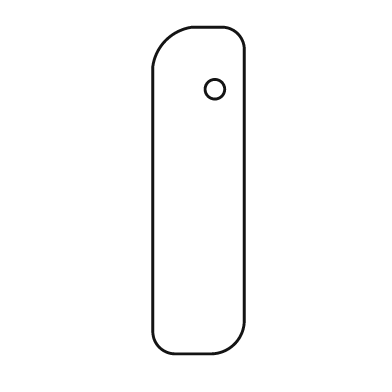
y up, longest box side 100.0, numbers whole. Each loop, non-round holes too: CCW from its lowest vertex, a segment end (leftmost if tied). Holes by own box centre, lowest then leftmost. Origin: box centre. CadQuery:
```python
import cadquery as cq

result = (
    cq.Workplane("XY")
    .moveTo(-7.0, -50.0)
    .lineTo(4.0, -50.0)
    .threePointArc((11.0, -47.0), (14.0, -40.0))
    .lineTo(14.0, 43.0)
    .threePointArc((12.0, 48.0), (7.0, 50.0))
    .lineTo(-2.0, 50.0)
    .threePointArc((-10.0, 46.0), (-14.0, 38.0))
    .lineTo(-14.0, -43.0)
    .threePointArc((-12.0, -48.0), (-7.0, -50.0))
    .close()
    .moveTo(5.0, 31.0)
    .circle(3.0)
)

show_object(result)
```